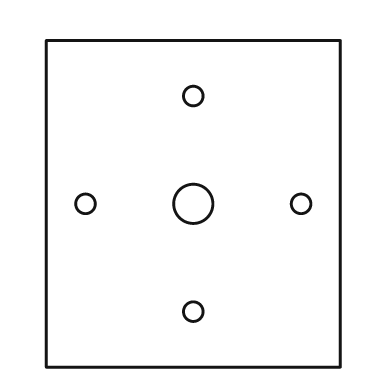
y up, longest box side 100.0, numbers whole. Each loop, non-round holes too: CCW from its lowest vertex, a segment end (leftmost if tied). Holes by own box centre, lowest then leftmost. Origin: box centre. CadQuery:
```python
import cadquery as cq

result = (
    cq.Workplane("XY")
    .moveTo(-45.0, -50.0)
    .lineTo(45.0, -50.0)
    .lineTo(45.0, 50.0)
    .lineTo(-45.0, 50.0)
    .close()
    .moveTo(0.0, -33.0)
    .circle(3.0)
    .moveTo(-33.0, 0.0)
    .circle(3.0)
    .moveTo(0.0, 0.0)
    .circle(6.0)
    .moveTo(33.0, 0.0)
    .circle(3.0)
    .moveTo(0.0, 33.0)
    .circle(3.0)
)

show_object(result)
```